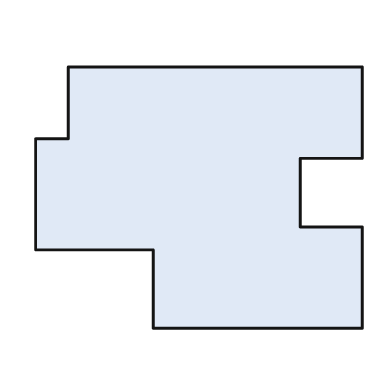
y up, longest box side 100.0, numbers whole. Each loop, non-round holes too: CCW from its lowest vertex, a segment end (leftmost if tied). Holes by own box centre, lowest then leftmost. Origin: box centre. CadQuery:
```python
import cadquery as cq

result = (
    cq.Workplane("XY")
    .moveTo(-14.0, -40.0)
    .lineTo(50.0, -40.0)
    .lineTo(50.0, -9.0)
    .lineTo(31.0, -9.0)
    .lineTo(31.0, 12.0)
    .lineTo(50.0, 12.0)
    .lineTo(50.0, 40.0)
    .lineTo(-40.0, 40.0)
    .lineTo(-40.0, 18.0)
    .lineTo(-50.0, 18.0)
    .lineTo(-50.0, -16.0)
    .lineTo(-14.0, -16.0)
    .close()
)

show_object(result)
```